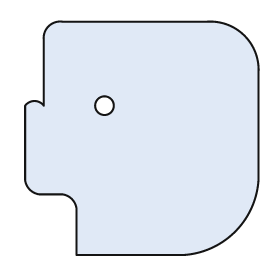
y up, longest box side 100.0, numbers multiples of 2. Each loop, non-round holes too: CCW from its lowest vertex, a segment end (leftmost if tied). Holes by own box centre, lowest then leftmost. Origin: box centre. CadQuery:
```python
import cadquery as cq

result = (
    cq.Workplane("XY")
    .moveTo(-28.0, -50.0)
    .lineTo(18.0, -50.0)
    .threePointArc((40.0, -40.0), (50.0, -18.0))
    .lineTo(50.0, 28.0)
    .threePointArc((44.0, 44.0), (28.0, 50.0))
    .lineTo(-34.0, 50.0)
    .threePointArc((-40.0, 48.0), (-42.0, 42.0))
    .lineTo(-42.0, 14.0)
    .threePointArc((-46.0, 16.0), (-50.0, 14.0))
    .lineTo(-50.0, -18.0)
    .threePointArc((-48.0, -22.0), (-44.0, -24.0))
    .lineTo(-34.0, -24.0)
    .threePointArc((-30.0, -26.0), (-28.0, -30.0))
    .close()
    .moveTo(-16.0, 14.0)
    .circle(4.0)
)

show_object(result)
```